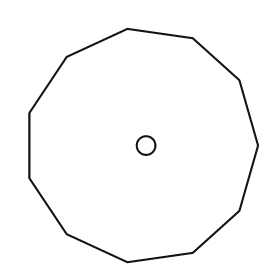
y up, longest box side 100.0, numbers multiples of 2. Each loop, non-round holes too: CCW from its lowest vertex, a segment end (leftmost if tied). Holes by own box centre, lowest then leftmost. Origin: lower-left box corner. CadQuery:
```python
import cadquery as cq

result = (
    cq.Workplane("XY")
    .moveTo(42.0, 0.0)
    .lineTo(70.0, 4.0)
    .lineTo(90.0, 22.0)
    .lineTo(98.0, 50.0)
    .lineTo(90.0, 78.0)
    .lineTo(70.0, 96.0)
    .lineTo(42.0, 100.0)
    .lineTo(16.0, 88.0)
    .lineTo(0.0, 64.0)
    .lineTo(0.0, 36.0)
    .lineTo(16.0, 12.0)
    .close()
    .moveTo(50.0, 50.0)
    .circle(4.0)
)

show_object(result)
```